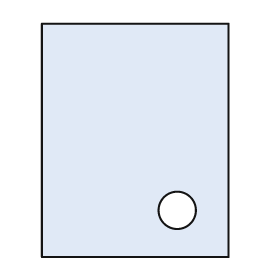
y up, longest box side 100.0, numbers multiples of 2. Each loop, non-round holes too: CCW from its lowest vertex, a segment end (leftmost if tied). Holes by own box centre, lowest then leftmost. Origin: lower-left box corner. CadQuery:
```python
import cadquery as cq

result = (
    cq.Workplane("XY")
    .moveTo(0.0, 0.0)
    .lineTo(80.0, 0.0)
    .lineTo(80.0, 100.0)
    .lineTo(0.0, 100.0)
    .close()
    .moveTo(58.0, 20.0)
    .circle(8.0)
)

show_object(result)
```